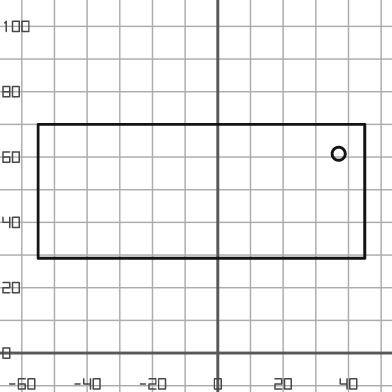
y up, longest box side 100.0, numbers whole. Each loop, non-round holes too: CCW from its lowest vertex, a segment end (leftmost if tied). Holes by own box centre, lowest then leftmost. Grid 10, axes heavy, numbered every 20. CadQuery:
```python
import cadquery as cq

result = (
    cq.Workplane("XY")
    .moveTo(-55.0, 29.0)
    .lineTo(45.0, 29.0)
    .lineTo(45.0, 70.0)
    .lineTo(-55.0, 70.0)
    .close()
    .moveTo(37.0, 61.0)
    .circle(2.0)
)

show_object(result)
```